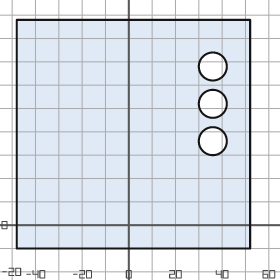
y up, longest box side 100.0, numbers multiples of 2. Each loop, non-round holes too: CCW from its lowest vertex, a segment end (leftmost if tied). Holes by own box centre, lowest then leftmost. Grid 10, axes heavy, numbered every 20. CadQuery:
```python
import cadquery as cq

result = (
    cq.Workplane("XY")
    .moveTo(-48.0, -10.0)
    .lineTo(52.0, -10.0)
    .lineTo(52.0, 88.0)
    .lineTo(-48.0, 88.0)
    .close()
    .moveTo(36.0, 36.0)
    .circle(6.0)
    .moveTo(36.0, 52.0)
    .circle(6.0)
    .moveTo(36.0, 68.0)
    .circle(6.0)
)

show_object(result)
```